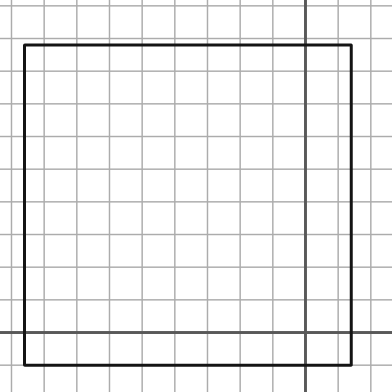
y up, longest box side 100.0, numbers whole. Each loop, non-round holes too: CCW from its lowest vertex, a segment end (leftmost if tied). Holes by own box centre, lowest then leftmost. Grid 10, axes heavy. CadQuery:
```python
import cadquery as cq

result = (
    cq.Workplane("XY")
    .moveTo(-86.0, -10.0)
    .lineTo(14.0, -10.0)
    .lineTo(14.0, 88.0)
    .lineTo(-86.0, 88.0)
    .close()
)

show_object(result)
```